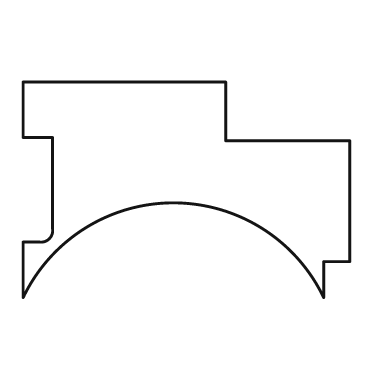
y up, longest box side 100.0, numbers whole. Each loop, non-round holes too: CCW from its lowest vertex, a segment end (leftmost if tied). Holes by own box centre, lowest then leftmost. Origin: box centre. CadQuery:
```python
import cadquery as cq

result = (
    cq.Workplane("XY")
    .moveTo(-50.0, -33.0)
    .threePointArc((-4.0, -4.0), (42.0, -33.0))
    .lineTo(42.0, -22.0)
    .lineTo(50.0, -22.0)
    .lineTo(50.0, 15.0)
    .lineTo(12.0, 15.0)
    .lineTo(12.0, 33.0)
    .lineTo(-50.0, 33.0)
    .lineTo(-50.0, 16.0)
    .lineTo(-41.0, 16.0)
    .lineTo(-41.0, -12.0)
    .threePointArc((-42.0, -15.0), (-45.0, -16.0))
    .lineTo(-50.0, -16.0)
    .close()
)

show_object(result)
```